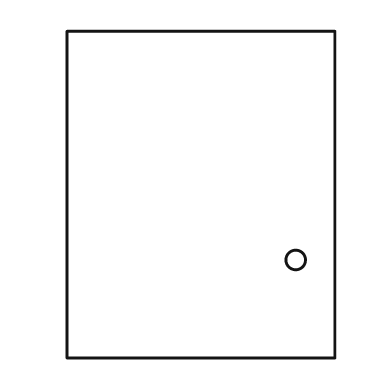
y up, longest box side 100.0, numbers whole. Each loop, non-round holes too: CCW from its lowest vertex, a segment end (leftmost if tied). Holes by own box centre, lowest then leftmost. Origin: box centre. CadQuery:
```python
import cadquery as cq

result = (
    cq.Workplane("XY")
    .moveTo(-41.0, -50.0)
    .lineTo(41.0, -50.0)
    .lineTo(41.0, 50.0)
    .lineTo(-41.0, 50.0)
    .close()
    .moveTo(29.0, -20.0)
    .circle(3.0)
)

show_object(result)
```